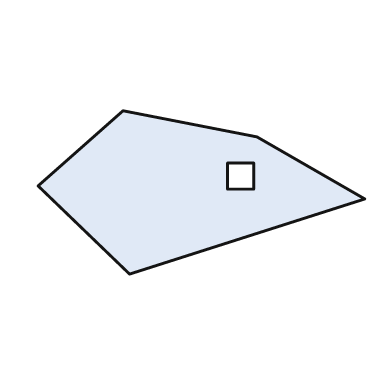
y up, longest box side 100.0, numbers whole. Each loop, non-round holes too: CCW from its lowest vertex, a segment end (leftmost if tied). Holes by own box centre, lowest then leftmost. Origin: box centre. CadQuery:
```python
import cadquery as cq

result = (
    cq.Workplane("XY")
    .moveTo(-22.0, -25.0)
    .lineTo(50.0, -2.0)
    .lineTo(17.0, 17.0)
    .lineTo(-24.0, 25.0)
    .lineTo(-50.0, 2.0)
    .close()
    .moveTo(8.0, 1.0)
    .lineTo(16.0, 1.0)
    .lineTo(16.0, 9.0)
    .lineTo(8.0, 9.0)
    .close()
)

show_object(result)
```